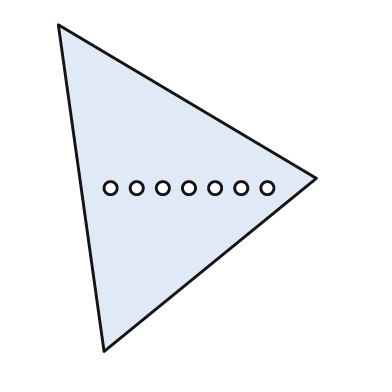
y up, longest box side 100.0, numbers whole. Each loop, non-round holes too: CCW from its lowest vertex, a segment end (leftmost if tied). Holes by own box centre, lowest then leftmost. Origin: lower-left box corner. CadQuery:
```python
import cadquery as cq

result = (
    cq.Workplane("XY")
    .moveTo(14.0, 0.0)
    .lineTo(79.0, 53.0)
    .lineTo(0.0, 100.0)
    .close()
    .moveTo(16.0, 50.0)
    .circle(2.0)
    .moveTo(24.0, 50.0)
    .circle(2.0)
    .moveTo(32.0, 50.0)
    .circle(2.0)
    .moveTo(40.0, 50.0)
    .circle(2.0)
    .moveTo(48.0, 50.0)
    .circle(2.0)
    .moveTo(56.0, 50.0)
    .circle(2.0)
    .moveTo(64.0, 50.0)
    .circle(2.0)
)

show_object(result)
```